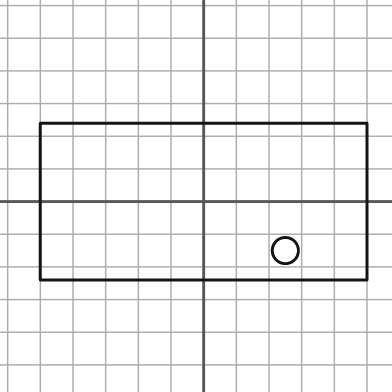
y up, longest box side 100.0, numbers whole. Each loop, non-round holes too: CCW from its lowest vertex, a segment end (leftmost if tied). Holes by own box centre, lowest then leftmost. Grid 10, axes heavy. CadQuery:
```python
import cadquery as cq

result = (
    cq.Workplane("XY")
    .moveTo(-50.0, -24.0)
    .lineTo(50.0, -24.0)
    .lineTo(50.0, 24.0)
    .lineTo(-50.0, 24.0)
    .close()
    .moveTo(25.0, -15.0)
    .circle(4.0)
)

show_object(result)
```